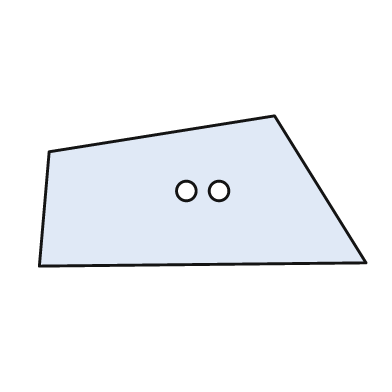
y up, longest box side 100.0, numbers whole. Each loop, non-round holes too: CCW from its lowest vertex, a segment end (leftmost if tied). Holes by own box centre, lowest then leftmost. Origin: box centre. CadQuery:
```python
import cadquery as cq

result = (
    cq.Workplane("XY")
    .moveTo(-50.0, -23.0)
    .lineTo(50.0, -22.0)
    .lineTo(22.0, 23.0)
    .lineTo(-47.0, 12.0)
    .close()
    .moveTo(-5.0, 0.0)
    .circle(3.0)
    .moveTo(5.0, 0.0)
    .circle(3.0)
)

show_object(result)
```